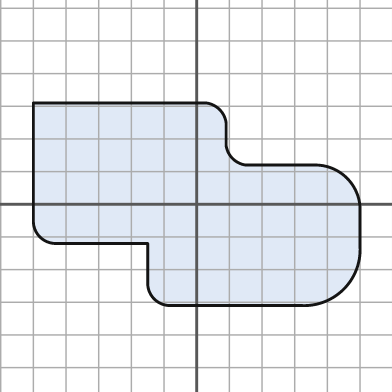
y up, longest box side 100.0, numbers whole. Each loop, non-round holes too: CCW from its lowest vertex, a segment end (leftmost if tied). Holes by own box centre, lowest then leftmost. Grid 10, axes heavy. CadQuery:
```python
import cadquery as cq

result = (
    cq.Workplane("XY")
    .moveTo(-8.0, -31.0)
    .lineTo(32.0, -31.0)
    .threePointArc((45.0, -26.0), (50.0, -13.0))
    .lineTo(50.0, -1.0)
    .threePointArc((46.0, 8.0), (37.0, 12.0))
    .lineTo(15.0, 12.0)
    .threePointArc((11.0, 14.0), (9.0, 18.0))
    .lineTo(9.0, 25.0)
    .threePointArc((7.0, 29.0), (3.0, 31.0))
    .lineTo(-50.0, 31.0)
    .lineTo(-50.0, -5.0)
    .threePointArc((-48.0, -10.0), (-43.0, -12.0))
    .lineTo(-15.0, -12.0)
    .lineTo(-15.0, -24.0)
    .threePointArc((-13.0, -29.0), (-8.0, -31.0))
    .close()
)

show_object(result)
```